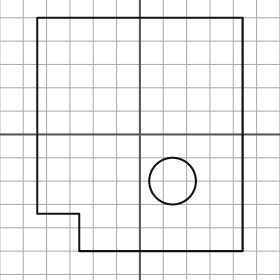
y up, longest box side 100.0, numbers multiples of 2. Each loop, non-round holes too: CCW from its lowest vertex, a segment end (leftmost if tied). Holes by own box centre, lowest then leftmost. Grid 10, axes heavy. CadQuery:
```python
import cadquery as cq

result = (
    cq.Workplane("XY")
    .moveTo(-26.0, -50.0)
    .lineTo(44.0, -50.0)
    .lineTo(44.0, 50.0)
    .lineTo(-44.0, 50.0)
    .lineTo(-44.0, -34.0)
    .lineTo(-26.0, -34.0)
    .close()
    .moveTo(14.0, -20.0)
    .circle(10.0)
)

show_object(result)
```